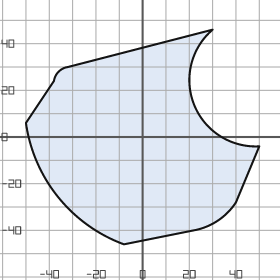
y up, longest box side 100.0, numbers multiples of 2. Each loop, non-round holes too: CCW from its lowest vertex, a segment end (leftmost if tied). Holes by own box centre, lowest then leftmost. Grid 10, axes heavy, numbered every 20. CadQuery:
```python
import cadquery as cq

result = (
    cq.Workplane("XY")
    .moveTo(-8.0, -46.0)
    .lineTo(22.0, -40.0)
    .threePointArc((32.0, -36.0), (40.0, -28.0))
    .lineTo(50.0, -4.0)
    .threePointArc((22.0, 14.0), (30.0, 46.0))
    .lineTo(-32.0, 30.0)
    .threePointArc((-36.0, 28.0), (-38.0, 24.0))
    .lineTo(-50.0, 6.0)
    .threePointArc((-36.0, -26.0), (-8.0, -46.0))
    .close()
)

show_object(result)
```